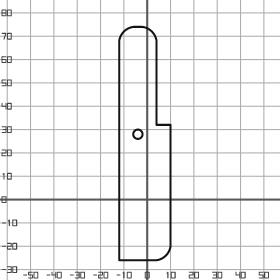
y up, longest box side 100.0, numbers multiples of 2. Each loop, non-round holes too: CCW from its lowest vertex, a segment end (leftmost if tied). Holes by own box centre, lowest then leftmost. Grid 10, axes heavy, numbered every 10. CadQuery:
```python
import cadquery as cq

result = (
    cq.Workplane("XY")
    .moveTo(-12.0, -26.0)
    .lineTo(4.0, -26.0)
    .threePointArc((8.0, -24.0), (10.0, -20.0))
    .lineTo(10.0, 32.0)
    .lineTo(4.0, 32.0)
    .lineTo(4.0, 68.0)
    .threePointArc((2.0, 72.0), (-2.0, 74.0))
    .lineTo(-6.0, 74.0)
    .threePointArc((-10.0, 72.0), (-12.0, 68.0))
    .close()
    .moveTo(-4.0, 28.0)
    .circle(2.0)
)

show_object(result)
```